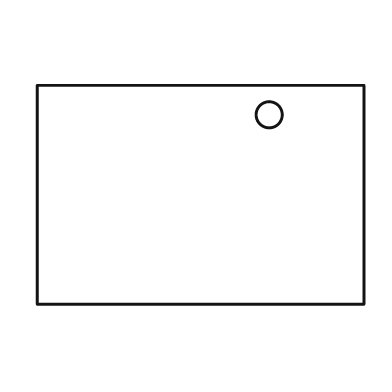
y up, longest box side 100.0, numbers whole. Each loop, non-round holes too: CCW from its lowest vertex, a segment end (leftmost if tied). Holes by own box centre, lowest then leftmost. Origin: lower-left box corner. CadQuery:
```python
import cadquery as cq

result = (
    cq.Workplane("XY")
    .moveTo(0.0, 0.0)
    .lineTo(100.0, 0.0)
    .lineTo(100.0, 67.0)
    .lineTo(0.0, 67.0)
    .close()
    .moveTo(71.0, 58.0)
    .circle(4.0)
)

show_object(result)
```